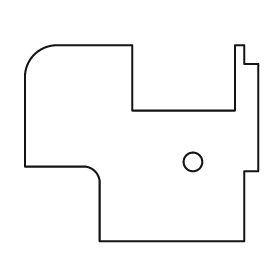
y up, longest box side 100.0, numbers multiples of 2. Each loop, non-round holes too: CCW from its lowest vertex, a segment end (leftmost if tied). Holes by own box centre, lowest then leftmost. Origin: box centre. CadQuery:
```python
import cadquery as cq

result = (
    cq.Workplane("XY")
    .moveTo(-18.0, -42.0)
    .lineTo(44.0, -42.0)
    .lineTo(44.0, -12.0)
    .lineTo(50.0, -12.0)
    .lineTo(50.0, 34.0)
    .lineTo(44.0, 34.0)
    .lineTo(44.0, 42.0)
    .lineTo(40.0, 42.0)
    .lineTo(40.0, 14.0)
    .lineTo(-4.0, 14.0)
    .lineTo(-4.0, 42.0)
    .lineTo(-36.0, 42.0)
    .threePointArc((-46.0, 38.0), (-50.0, 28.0))
    .lineTo(-50.0, -10.0)
    .lineTo(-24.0, -10.0)
    .threePointArc((-20.0, -12.0), (-18.0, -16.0))
    .close()
    .moveTo(22.0, -8.0)
    .circle(4.0)
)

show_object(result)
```